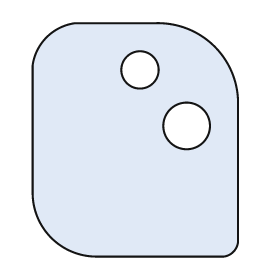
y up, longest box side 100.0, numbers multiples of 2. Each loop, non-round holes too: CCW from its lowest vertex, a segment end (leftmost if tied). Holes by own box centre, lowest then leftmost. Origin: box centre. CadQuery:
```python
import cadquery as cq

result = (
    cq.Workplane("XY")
    .moveTo(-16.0, -50.0)
    .lineTo(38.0, -50.0)
    .threePointArc((42.0, -48.0), (44.0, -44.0))
    .lineTo(44.0, 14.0)
    .threePointArc((34.0, 40.0), (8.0, 50.0))
    .lineTo(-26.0, 50.0)
    .threePointArc((-38.0, 44.0), (-44.0, 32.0))
    .lineTo(-44.0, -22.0)
    .threePointArc((-36.0, -42.0), (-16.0, -50.0))
    .close()
    .moveTo(22.0, 6.0)
    .circle(10.0)
    .moveTo(2.0, 30.0)
    .circle(8.0)
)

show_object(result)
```